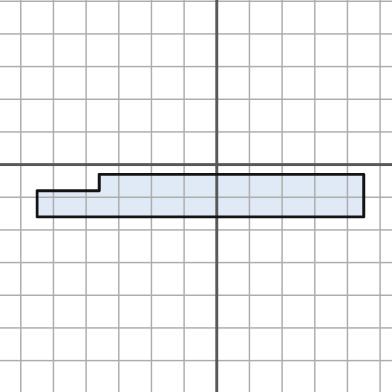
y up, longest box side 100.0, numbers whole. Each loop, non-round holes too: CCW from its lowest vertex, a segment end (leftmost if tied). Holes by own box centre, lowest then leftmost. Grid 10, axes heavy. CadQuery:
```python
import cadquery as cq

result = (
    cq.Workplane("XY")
    .moveTo(-55.0, -16.0)
    .lineTo(45.0, -16.0)
    .lineTo(45.0, -3.0)
    .lineTo(-36.0, -3.0)
    .lineTo(-36.0, -8.0)
    .lineTo(-55.0, -8.0)
    .close()
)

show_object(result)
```